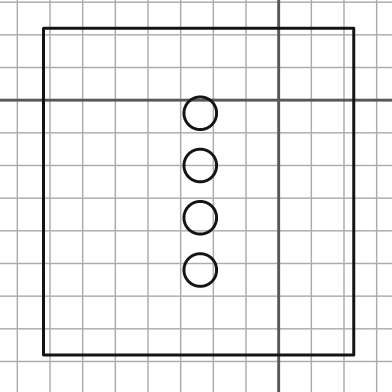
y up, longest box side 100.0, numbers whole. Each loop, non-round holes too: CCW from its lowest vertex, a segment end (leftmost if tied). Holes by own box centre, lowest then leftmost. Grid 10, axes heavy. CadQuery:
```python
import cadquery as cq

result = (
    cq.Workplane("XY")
    .moveTo(-72.0, -78.0)
    .lineTo(23.0, -78.0)
    .lineTo(23.0, 22.0)
    .lineTo(-72.0, 22.0)
    .close()
    .moveTo(-24.0, -52.0)
    .circle(5.0)
    .moveTo(-24.0, -36.0)
    .circle(5.0)
    .moveTo(-24.0, -20.0)
    .circle(5.0)
    .moveTo(-24.0, -4.0)
    .circle(5.0)
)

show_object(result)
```